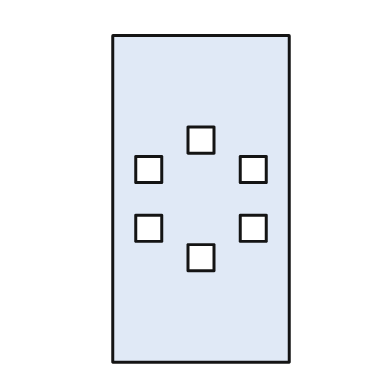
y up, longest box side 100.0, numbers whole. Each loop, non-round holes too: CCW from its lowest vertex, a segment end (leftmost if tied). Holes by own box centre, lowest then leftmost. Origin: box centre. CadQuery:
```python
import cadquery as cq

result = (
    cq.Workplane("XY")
    .moveTo(-27.0, -50.0)
    .lineTo(27.0, -50.0)
    .lineTo(27.0, 50.0)
    .lineTo(-27.0, 50.0)
    .close()
    .moveTo(-4.0, -22.0)
    .lineTo(4.0, -22.0)
    .lineTo(4.0, -14.0)
    .lineTo(-4.0, -14.0)
    .close()
    .moveTo(-20.0, -13.0)
    .lineTo(-12.0, -13.0)
    .lineTo(-12.0, -5.0)
    .lineTo(-20.0, -5.0)
    .close()
    .moveTo(12.0, -13.0)
    .lineTo(20.0, -13.0)
    .lineTo(20.0, -5.0)
    .lineTo(12.0, -5.0)
    .close()
    .moveTo(-20.0, 5.0)
    .lineTo(-12.0, 5.0)
    .lineTo(-12.0, 13.0)
    .lineTo(-20.0, 13.0)
    .close()
    .moveTo(12.0, 5.0)
    .lineTo(20.0, 5.0)
    .lineTo(20.0, 13.0)
    .lineTo(12.0, 13.0)
    .close()
    .moveTo(-4.0, 14.0)
    .lineTo(4.0, 14.0)
    .lineTo(4.0, 22.0)
    .lineTo(-4.0, 22.0)
    .close()
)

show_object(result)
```